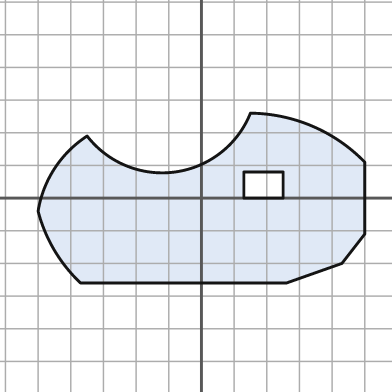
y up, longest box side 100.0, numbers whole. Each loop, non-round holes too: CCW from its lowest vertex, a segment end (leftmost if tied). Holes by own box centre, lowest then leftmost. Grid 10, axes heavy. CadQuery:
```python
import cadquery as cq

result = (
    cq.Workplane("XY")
    .moveTo(-37.0, -26.0)
    .lineTo(26.0, -26.0)
    .lineTo(43.0, -20.0)
    .lineTo(50.0, -11.0)
    .lineTo(50.0, 11.0)
    .threePointArc((34.0, 22.0), (15.0, 26.0))
    .threePointArc((-8.0, 8.0), (-35.0, 19.0))
    .threePointArc((-45.0, 9.0), (-50.0, -4.0))
    .threePointArc((-45.0, -16.0), (-37.0, -26.0))
    .close()
    .moveTo(13.0, 0.0)
    .lineTo(25.0, 0.0)
    .lineTo(25.0, 8.0)
    .lineTo(13.0, 8.0)
    .close()
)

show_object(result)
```